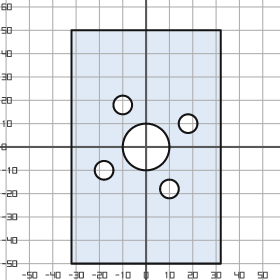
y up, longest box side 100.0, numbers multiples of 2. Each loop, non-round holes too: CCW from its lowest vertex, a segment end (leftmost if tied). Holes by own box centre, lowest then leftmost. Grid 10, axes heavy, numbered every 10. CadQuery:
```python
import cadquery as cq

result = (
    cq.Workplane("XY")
    .moveTo(-32.0, -50.0)
    .lineTo(32.0, -50.0)
    .lineTo(32.0, 50.0)
    .lineTo(-32.0, 50.0)
    .close()
    .moveTo(10.0, -18.0)
    .circle(4.0)
    .moveTo(-18.0, -10.0)
    .circle(4.0)
    .moveTo(0.0, 0.0)
    .circle(10.0)
    .moveTo(18.0, 10.0)
    .circle(4.0)
    .moveTo(-10.0, 18.0)
    .circle(4.0)
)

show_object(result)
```